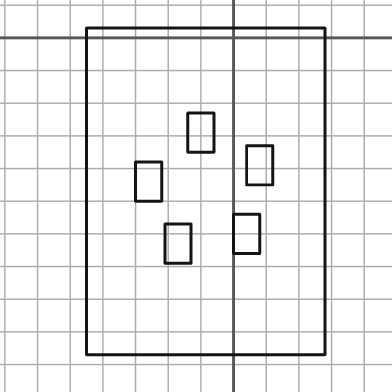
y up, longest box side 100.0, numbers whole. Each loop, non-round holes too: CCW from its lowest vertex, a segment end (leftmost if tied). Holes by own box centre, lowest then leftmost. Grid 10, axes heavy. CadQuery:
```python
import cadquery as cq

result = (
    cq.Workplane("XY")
    .moveTo(-45.0, -97.0)
    .lineTo(28.0, -97.0)
    .lineTo(28.0, 3.0)
    .lineTo(-45.0, 3.0)
    .close()
    .moveTo(-21.0, -69.0)
    .lineTo(-13.0, -69.0)
    .lineTo(-13.0, -57.0)
    .lineTo(-21.0, -57.0)
    .close()
    .moveTo(0.0, -66.0)
    .lineTo(8.0, -66.0)
    .lineTo(8.0, -54.0)
    .lineTo(0.0, -54.0)
    .close()
    .moveTo(-30.0, -50.0)
    .lineTo(-22.0, -50.0)
    .lineTo(-22.0, -38.0)
    .lineTo(-30.0, -38.0)
    .close()
    .moveTo(4.0, -45.0)
    .lineTo(12.0, -45.0)
    .lineTo(12.0, -33.0)
    .lineTo(4.0, -33.0)
    .close()
    .moveTo(-14.0, -35.0)
    .lineTo(-6.0, -35.0)
    .lineTo(-6.0, -23.0)
    .lineTo(-14.0, -23.0)
    .close()
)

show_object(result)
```